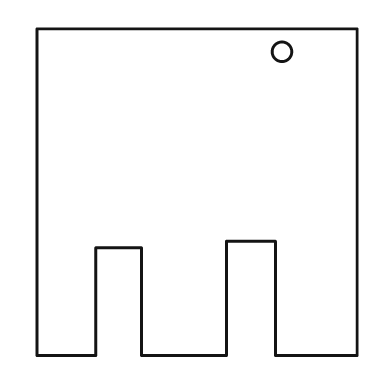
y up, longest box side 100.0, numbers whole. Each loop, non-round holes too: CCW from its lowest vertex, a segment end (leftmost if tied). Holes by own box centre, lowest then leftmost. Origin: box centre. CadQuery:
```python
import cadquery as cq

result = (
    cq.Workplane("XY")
    .moveTo(-49.0, -50.0)
    .lineTo(-31.0, -50.0)
    .lineTo(-31.0, -17.0)
    .lineTo(-17.0, -17.0)
    .lineTo(-17.0, -50.0)
    .lineTo(9.0, -50.0)
    .lineTo(9.0, -15.0)
    .lineTo(24.0, -15.0)
    .lineTo(24.0, -50.0)
    .lineTo(49.0, -50.0)
    .lineTo(49.0, 50.0)
    .lineTo(-49.0, 50.0)
    .close()
    .moveTo(26.0, 43.0)
    .circle(3.0)
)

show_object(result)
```